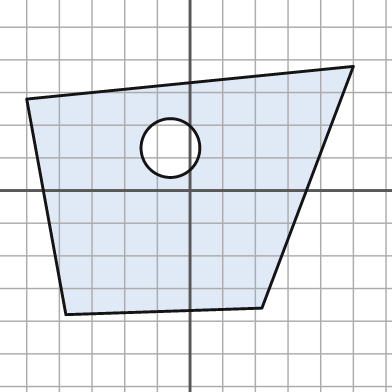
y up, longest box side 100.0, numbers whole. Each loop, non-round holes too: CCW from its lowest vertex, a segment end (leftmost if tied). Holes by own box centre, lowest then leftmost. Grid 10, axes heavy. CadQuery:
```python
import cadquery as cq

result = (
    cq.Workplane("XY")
    .moveTo(-38.0, -38.0)
    .lineTo(22.0, -36.0)
    .lineTo(50.0, 38.0)
    .lineTo(-50.0, 28.0)
    .close()
    .moveTo(-6.0, 13.0)
    .circle(9.0)
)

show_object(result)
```